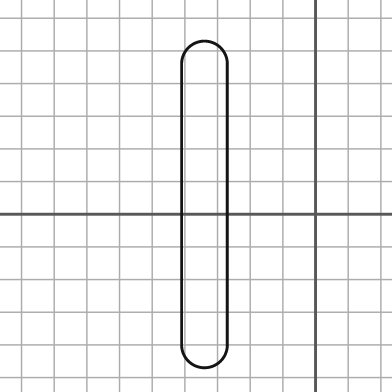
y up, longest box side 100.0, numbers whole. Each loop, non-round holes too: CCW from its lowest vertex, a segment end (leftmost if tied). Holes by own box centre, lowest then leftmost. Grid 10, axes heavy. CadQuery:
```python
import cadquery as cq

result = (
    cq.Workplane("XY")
    .moveTo(-41.0, -40.0)
    .threePointArc((-34.0, -47.0), (-27.0, -40.0))
    .lineTo(-27.0, 46.0)
    .threePointArc((-34.0, 53.0), (-41.0, 46.0))
    .close()
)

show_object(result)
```